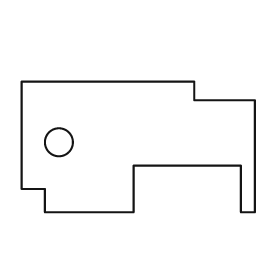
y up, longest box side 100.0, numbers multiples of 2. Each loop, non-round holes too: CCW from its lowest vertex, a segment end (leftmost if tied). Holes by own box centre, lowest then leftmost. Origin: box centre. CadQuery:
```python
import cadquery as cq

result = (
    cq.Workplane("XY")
    .moveTo(-40.0, -28.0)
    .lineTo(-2.0, -28.0)
    .lineTo(-2.0, -8.0)
    .lineTo(44.0, -8.0)
    .lineTo(44.0, -28.0)
    .lineTo(50.0, -28.0)
    .lineTo(50.0, 20.0)
    .lineTo(24.0, 20.0)
    .lineTo(24.0, 28.0)
    .lineTo(-50.0, 28.0)
    .lineTo(-50.0, -18.0)
    .lineTo(-40.0, -18.0)
    .close()
    .moveTo(-34.0, 2.0)
    .circle(6.0)
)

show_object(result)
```